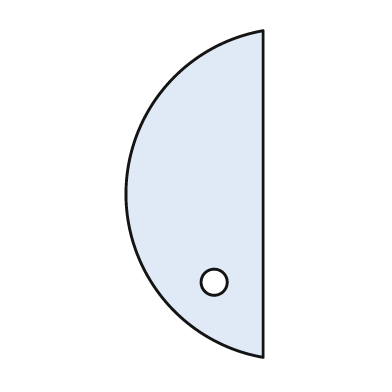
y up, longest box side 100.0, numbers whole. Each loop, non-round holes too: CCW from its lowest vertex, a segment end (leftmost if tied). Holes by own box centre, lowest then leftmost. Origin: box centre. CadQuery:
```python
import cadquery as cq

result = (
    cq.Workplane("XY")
    .moveTo(21.0, -50.0)
    .lineTo(21.0, 50.0)
    .threePointArc((-21.0, 0.0), (21.0, -50.0))
    .close()
    .moveTo(6.0, -27.0)
    .circle(4.0)
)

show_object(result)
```